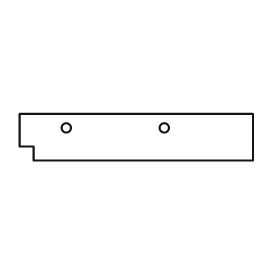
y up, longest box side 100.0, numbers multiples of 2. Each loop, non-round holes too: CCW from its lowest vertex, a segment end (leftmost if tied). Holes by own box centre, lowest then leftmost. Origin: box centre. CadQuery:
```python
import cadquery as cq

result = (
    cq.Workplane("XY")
    .moveTo(-44.0, -10.0)
    .lineTo(50.0, -10.0)
    .lineTo(50.0, 10.0)
    .lineTo(-50.0, 10.0)
    .lineTo(-50.0, -4.0)
    .lineTo(-44.0, -4.0)
    .close()
    .moveTo(-30.0, 4.0)
    .circle(2.0)
    .moveTo(12.0, 4.0)
    .circle(2.0)
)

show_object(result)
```